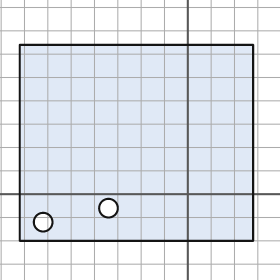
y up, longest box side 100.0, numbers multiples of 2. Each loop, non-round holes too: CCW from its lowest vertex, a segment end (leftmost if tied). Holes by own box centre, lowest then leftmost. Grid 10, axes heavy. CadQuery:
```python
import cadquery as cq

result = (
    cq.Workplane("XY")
    .moveTo(-72.0, -20.0)
    .lineTo(28.0, -20.0)
    .lineTo(28.0, 64.0)
    .lineTo(-72.0, 64.0)
    .close()
    .moveTo(-62.0, -12.0)
    .circle(4.0)
    .moveTo(-34.0, -6.0)
    .circle(4.0)
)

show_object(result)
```